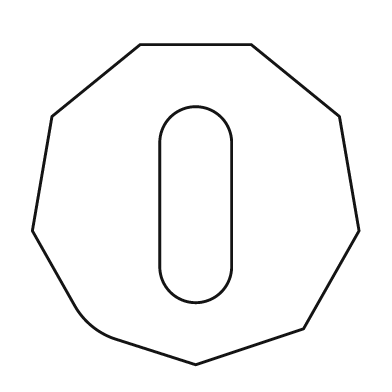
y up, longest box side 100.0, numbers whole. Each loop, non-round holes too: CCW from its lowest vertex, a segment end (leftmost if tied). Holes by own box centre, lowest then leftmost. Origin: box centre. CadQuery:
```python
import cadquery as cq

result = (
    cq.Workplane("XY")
    .moveTo(0.0, -49.0)
    .lineTo(33.0, -38.0)
    .lineTo(50.0, -8.0)
    .lineTo(44.0, 27.0)
    .lineTo(17.0, 49.0)
    .lineTo(-17.0, 49.0)
    .lineTo(-44.0, 27.0)
    .lineTo(-50.0, -8.0)
    .lineTo(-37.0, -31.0)
    .threePointArc((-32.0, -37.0), (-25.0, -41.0))
    .close()
    .moveTo(-11.0, -19.0)
    .threePointArc((0.0, -30.0), (11.0, -19.0))
    .lineTo(11.0, 19.0)
    .threePointArc((0.0, 30.0), (-11.0, 19.0))
    .close()
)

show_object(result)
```